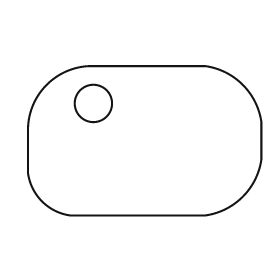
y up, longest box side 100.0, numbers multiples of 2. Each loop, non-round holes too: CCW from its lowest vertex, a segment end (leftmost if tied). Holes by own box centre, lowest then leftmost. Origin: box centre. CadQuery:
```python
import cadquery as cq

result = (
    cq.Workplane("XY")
    .moveTo(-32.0, -32.0)
    .lineTo(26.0, -32.0)
    .threePointArc((42.0, -24.0), (50.0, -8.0))
    .lineTo(50.0, 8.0)
    .threePointArc((42.0, 24.0), (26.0, 32.0))
    .lineTo(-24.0, 32.0)
    .threePointArc((-42.0, 24.0), (-50.0, 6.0))
    .lineTo(-50.0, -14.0)
    .threePointArc((-44.0, -26.0), (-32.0, -32.0))
    .close()
    .moveTo(-22.0, 16.0)
    .circle(8.0)
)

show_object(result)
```